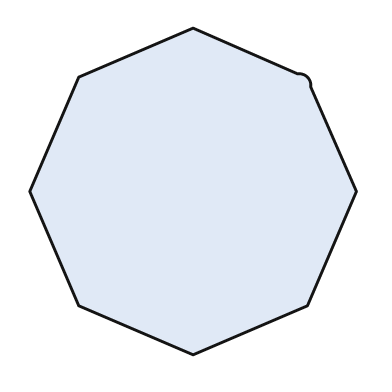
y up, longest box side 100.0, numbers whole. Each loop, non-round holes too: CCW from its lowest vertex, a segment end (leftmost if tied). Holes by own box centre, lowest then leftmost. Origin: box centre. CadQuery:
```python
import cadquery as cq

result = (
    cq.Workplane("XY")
    .moveTo(0.0, -50.0)
    .lineTo(35.0, -35.0)
    .lineTo(50.0, 0.0)
    .lineTo(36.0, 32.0)
    .threePointArc((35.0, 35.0), (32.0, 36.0))
    .lineTo(0.0, 50.0)
    .lineTo(-35.0, 35.0)
    .lineTo(-50.0, 0.0)
    .lineTo(-35.0, -35.0)
    .close()
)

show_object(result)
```